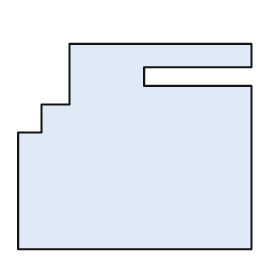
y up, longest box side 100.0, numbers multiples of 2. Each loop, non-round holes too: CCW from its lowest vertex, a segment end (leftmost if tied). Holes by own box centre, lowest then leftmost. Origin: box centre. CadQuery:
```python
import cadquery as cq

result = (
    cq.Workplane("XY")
    .moveTo(-50.0, -44.0)
    .lineTo(50.0, -44.0)
    .lineTo(50.0, 26.0)
    .lineTo(4.0, 26.0)
    .lineTo(4.0, 34.0)
    .lineTo(50.0, 34.0)
    .lineTo(50.0, 44.0)
    .lineTo(-28.0, 44.0)
    .lineTo(-28.0, 18.0)
    .lineTo(-40.0, 18.0)
    .lineTo(-40.0, 6.0)
    .lineTo(-50.0, 6.0)
    .close()
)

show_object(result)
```